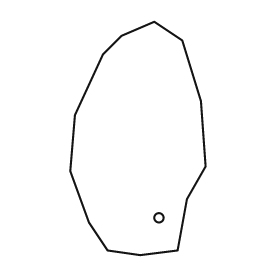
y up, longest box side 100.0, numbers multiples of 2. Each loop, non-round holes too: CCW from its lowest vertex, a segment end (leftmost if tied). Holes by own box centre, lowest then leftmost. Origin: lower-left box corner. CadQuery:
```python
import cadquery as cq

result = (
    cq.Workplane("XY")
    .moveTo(30.0, 0.0)
    .lineTo(46.0, 2.0)
    .lineTo(50.0, 24.0)
    .lineTo(58.0, 38.0)
    .lineTo(56.0, 66.0)
    .lineTo(48.0, 92.0)
    .lineTo(36.0, 100.0)
    .lineTo(22.0, 94.0)
    .lineTo(14.0, 86.0)
    .lineTo(2.0, 60.0)
    .lineTo(0.0, 36.0)
    .lineTo(8.0, 14.0)
    .lineTo(16.0, 2.0)
    .close()
    .moveTo(38.0, 16.0)
    .circle(2.0)
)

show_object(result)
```